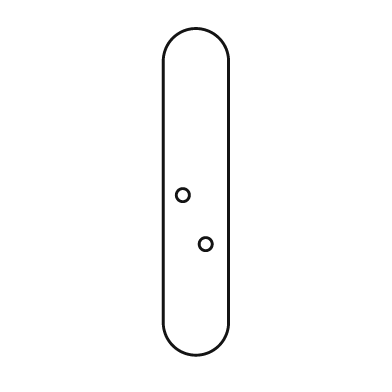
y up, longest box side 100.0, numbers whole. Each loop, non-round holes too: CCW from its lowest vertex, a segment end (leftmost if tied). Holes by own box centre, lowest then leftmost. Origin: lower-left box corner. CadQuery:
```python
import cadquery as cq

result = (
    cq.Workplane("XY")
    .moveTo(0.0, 10.0)
    .threePointArc((10.0, 0.0), (20.0, 10.0))
    .lineTo(20.0, 90.0)
    .threePointArc((10.0, 100.0), (0.0, 90.0))
    .close()
    .moveTo(13.0, 34.0)
    .circle(2.0)
    .moveTo(6.0, 49.0)
    .circle(2.0)
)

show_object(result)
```